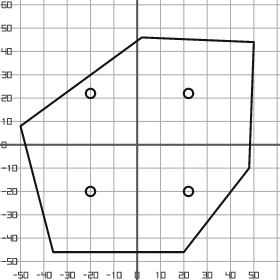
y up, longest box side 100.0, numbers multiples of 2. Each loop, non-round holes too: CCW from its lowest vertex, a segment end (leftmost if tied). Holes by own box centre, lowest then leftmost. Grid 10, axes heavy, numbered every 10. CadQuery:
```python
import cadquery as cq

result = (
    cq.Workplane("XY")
    .moveTo(-36.0, -46.0)
    .lineTo(20.0, -46.0)
    .lineTo(48.0, -10.0)
    .lineTo(50.0, 44.0)
    .lineTo(2.0, 46.0)
    .lineTo(-50.0, 8.0)
    .close()
    .moveTo(-20.0, -20.0)
    .circle(2.0)
    .moveTo(22.0, -20.0)
    .circle(2.0)
    .moveTo(-20.0, 22.0)
    .circle(2.0)
    .moveTo(22.0, 22.0)
    .circle(2.0)
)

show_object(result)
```